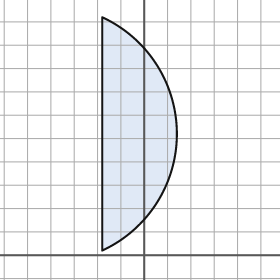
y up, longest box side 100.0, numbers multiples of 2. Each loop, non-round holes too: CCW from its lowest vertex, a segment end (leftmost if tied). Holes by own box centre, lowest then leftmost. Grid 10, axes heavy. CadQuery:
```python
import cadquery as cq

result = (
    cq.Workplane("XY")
    .moveTo(-18.0, 2.0)
    .threePointArc((14.0, 52.0), (-18.0, 102.0))
    .close()
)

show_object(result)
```